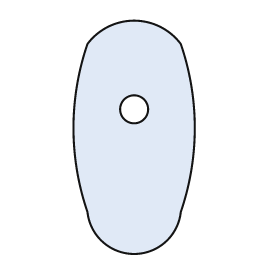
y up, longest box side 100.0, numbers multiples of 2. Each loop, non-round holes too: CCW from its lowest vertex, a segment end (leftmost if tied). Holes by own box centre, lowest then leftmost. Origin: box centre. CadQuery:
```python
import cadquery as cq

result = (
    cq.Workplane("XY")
    .moveTo(-20.0, -32.0)
    .threePointArc((0.0, -50.0), (20.0, -32.0))
    .threePointArc((26.0, 4.0), (20.0, 40.0))
    .threePointArc((0.0, 50.0), (-20.0, 40.0))
    .threePointArc((-26.0, 4.0), (-20.0, -32.0))
    .close()
    .moveTo(0.0, 12.0)
    .circle(6.0)
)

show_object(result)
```